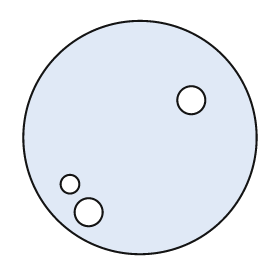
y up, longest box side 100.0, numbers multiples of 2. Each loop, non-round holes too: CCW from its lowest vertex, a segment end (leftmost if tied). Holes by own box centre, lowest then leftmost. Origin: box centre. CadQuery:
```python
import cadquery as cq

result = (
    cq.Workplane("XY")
    .moveTo(0.0, 0.0)
    .circle(50.0)
    .moveTo(-22.0, -32.0)
    .circle(6.0)
    .moveTo(-30.0, -20.0)
    .circle(4.0)
    .moveTo(22.0, 16.0)
    .circle(6.0)
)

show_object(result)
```